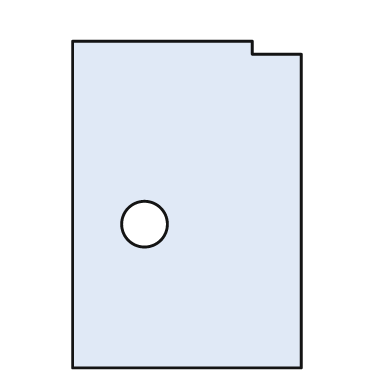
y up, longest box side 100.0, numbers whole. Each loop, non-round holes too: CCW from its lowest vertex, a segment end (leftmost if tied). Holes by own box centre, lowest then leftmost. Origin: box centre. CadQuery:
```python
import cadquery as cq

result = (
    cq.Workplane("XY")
    .moveTo(-35.0, -50.0)
    .lineTo(35.0, -50.0)
    .lineTo(35.0, 46.0)
    .lineTo(20.0, 46.0)
    .lineTo(20.0, 50.0)
    .lineTo(-35.0, 50.0)
    .close()
    .moveTo(-13.0, -6.0)
    .circle(7.0)
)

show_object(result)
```